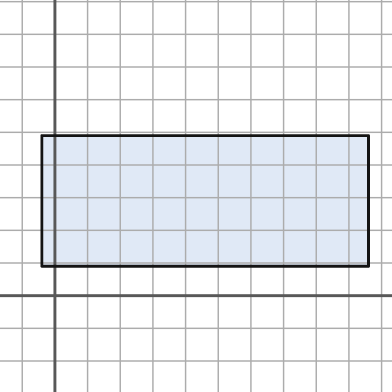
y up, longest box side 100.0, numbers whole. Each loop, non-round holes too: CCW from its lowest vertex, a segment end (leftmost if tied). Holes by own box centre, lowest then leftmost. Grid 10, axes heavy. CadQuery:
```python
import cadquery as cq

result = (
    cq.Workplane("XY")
    .moveTo(-4.0, 9.0)
    .lineTo(96.0, 9.0)
    .lineTo(96.0, 49.0)
    .lineTo(-4.0, 49.0)
    .close()
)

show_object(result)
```